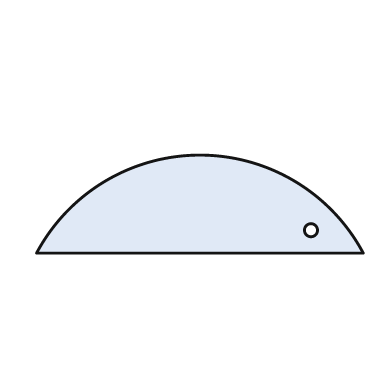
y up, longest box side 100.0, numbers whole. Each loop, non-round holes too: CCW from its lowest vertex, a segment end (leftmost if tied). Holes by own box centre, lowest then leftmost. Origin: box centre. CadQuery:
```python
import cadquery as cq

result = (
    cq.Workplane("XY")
    .moveTo(-50.0, -15.0)
    .lineTo(50.0, -15.0)
    .threePointArc((0.0, 15.0), (-50.0, -15.0))
    .close()
    .moveTo(34.0, -8.0)
    .circle(2.0)
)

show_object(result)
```